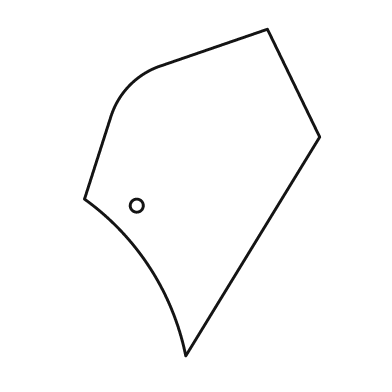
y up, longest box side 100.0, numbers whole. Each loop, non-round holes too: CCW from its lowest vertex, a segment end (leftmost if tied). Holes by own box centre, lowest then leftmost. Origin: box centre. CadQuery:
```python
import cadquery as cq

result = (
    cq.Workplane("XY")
    .moveTo(-5.0, -50.0)
    .lineTo(36.0, 17.0)
    .lineTo(20.0, 50.0)
    .lineTo(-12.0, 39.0)
    .threePointArc((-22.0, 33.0), (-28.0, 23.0))
    .lineTo(-36.0, -2.0)
    .threePointArc((-16.0, -23.0), (-5.0, -50.0))
    .close()
    .moveTo(-20.0, -4.0)
    .circle(2.0)
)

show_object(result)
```